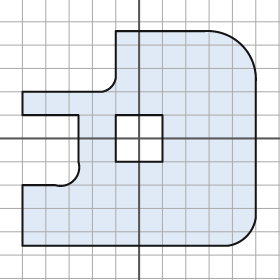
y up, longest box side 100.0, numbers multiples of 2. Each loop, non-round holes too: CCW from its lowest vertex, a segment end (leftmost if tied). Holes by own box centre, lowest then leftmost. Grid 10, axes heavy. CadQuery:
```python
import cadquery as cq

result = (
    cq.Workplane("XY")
    .moveTo(-50.0, -46.0)
    .lineTo(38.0, -46.0)
    .threePointArc((46.0, -42.0), (50.0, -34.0))
    .lineTo(50.0, 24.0)
    .threePointArc((44.0, 40.0), (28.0, 46.0))
    .lineTo(-10.0, 46.0)
    .lineTo(-10.0, 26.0)
    .threePointArc((-12.0, 22.0), (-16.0, 20.0))
    .lineTo(-50.0, 20.0)
    .lineTo(-50.0, 10.0)
    .lineTo(-26.0, 10.0)
    .lineTo(-26.0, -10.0)
    .threePointArc((-28.0, -18.0), (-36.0, -20.0))
    .lineTo(-50.0, -20.0)
    .close()
    .moveTo(-10.0, -10.0)
    .lineTo(10.0, -10.0)
    .lineTo(10.0, 10.0)
    .lineTo(-10.0, 10.0)
    .close()
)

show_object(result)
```